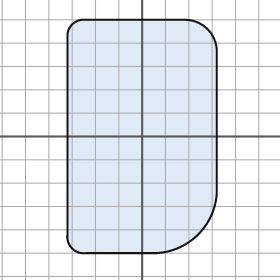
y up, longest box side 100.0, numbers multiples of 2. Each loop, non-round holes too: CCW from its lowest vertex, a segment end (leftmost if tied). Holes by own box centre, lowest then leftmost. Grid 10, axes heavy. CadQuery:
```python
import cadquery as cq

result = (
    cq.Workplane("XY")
    .moveTo(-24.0, -50.0)
    .lineTo(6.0, -50.0)
    .threePointArc((24.0, -42.0), (32.0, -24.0))
    .lineTo(32.0, 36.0)
    .threePointArc((28.0, 46.0), (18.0, 50.0))
    .lineTo(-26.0, 50.0)
    .threePointArc((-30.0, 48.0), (-32.0, 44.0))
    .lineTo(-32.0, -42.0)
    .threePointArc((-30.0, -48.0), (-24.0, -50.0))
    .close()
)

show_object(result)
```